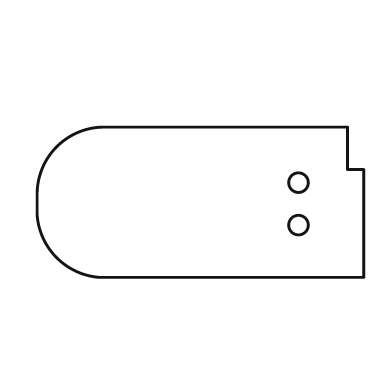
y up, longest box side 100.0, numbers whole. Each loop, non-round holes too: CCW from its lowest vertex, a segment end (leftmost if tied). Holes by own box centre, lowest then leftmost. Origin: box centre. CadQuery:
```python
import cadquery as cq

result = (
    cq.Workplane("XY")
    .moveTo(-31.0, -23.0)
    .lineTo(50.0, -23.0)
    .lineTo(50.0, 10.0)
    .lineTo(45.0, 10.0)
    .lineTo(45.0, 23.0)
    .lineTo(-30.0, 23.0)
    .threePointArc((-44.0, 17.0), (-50.0, 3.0))
    .lineTo(-50.0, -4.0)
    .threePointArc((-44.0, -17.0), (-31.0, -23.0))
    .close()
    .moveTo(30.0, -7.0)
    .circle(3.0)
    .moveTo(30.0, 6.0)
    .circle(3.0)
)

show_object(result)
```